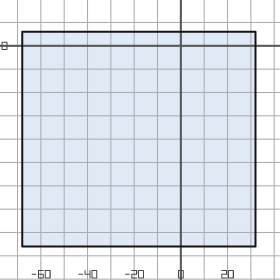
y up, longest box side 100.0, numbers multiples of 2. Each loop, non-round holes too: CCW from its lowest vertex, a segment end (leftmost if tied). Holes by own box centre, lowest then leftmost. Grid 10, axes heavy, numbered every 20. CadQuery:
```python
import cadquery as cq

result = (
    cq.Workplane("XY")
    .moveTo(-68.0, -86.0)
    .lineTo(32.0, -86.0)
    .lineTo(32.0, 6.0)
    .lineTo(-68.0, 6.0)
    .close()
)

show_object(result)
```